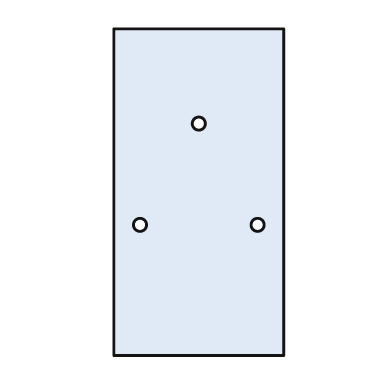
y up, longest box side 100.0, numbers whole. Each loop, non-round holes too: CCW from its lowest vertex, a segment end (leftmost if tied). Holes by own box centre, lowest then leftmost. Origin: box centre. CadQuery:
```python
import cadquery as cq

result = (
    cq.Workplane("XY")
    .moveTo(-26.0, -50.0)
    .lineTo(26.0, -50.0)
    .lineTo(26.0, 50.0)
    .lineTo(-26.0, 50.0)
    .close()
    .moveTo(-18.0, -10.0)
    .circle(2.0)
    .moveTo(18.0, -10.0)
    .circle(2.0)
    .moveTo(0.0, 21.0)
    .circle(2.0)
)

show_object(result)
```